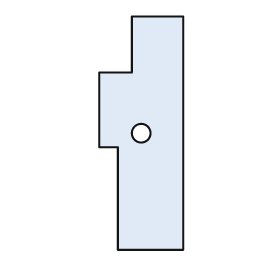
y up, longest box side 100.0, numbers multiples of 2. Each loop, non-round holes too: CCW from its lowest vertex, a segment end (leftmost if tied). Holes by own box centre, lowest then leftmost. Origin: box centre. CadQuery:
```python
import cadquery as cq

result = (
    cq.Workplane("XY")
    .moveTo(-10.0, -50.0)
    .lineTo(18.0, -50.0)
    .lineTo(18.0, 50.0)
    .lineTo(-4.0, 50.0)
    .lineTo(-4.0, 26.0)
    .lineTo(-18.0, 26.0)
    .lineTo(-18.0, -6.0)
    .lineTo(-10.0, -6.0)
    .close()
    .moveTo(0.0, 0.0)
    .circle(4.0)
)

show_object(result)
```